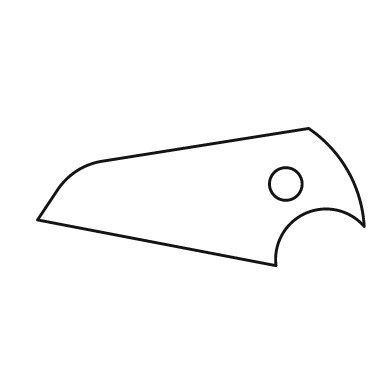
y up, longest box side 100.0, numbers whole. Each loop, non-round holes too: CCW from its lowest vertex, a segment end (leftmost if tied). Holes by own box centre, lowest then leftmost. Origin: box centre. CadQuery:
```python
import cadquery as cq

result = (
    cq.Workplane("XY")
    .moveTo(23.0, -21.0)
    .threePointArc((32.0, -5.0), (50.0, -9.0))
    .threePointArc((45.0, 8.0), (33.0, 21.0))
    .lineTo(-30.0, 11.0)
    .threePointArc((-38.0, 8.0), (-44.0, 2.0))
    .lineTo(-50.0, -7.0)
    .close()
    .moveTo(26.0, 4.0)
    .circle(5.0)
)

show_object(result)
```